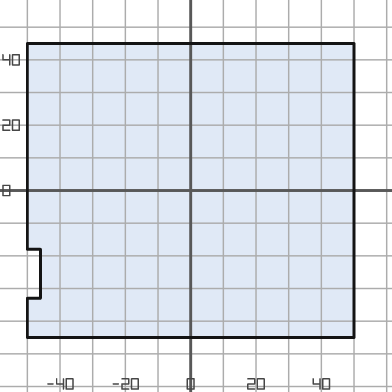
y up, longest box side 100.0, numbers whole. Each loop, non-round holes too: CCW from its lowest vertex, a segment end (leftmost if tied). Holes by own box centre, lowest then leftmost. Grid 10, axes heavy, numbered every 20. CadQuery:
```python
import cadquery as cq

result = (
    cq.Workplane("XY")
    .moveTo(-50.0, -45.0)
    .lineTo(50.0, -45.0)
    .lineTo(50.0, 45.0)
    .lineTo(-50.0, 45.0)
    .lineTo(-50.0, -18.0)
    .lineTo(-46.0, -18.0)
    .lineTo(-46.0, -33.0)
    .lineTo(-50.0, -33.0)
    .close()
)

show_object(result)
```